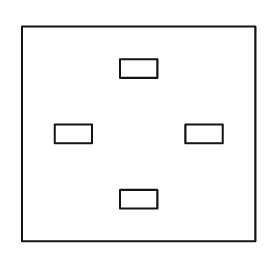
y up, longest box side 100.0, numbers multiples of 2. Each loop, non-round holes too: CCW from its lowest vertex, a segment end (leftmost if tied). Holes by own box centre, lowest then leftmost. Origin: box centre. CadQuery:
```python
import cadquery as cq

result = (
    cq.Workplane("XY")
    .moveTo(-50.0, -46.0)
    .lineTo(50.0, -46.0)
    .lineTo(50.0, 46.0)
    .lineTo(-50.0, 46.0)
    .close()
    .moveTo(-8.0, -32.0)
    .lineTo(8.0, -32.0)
    .lineTo(8.0, -24.0)
    .lineTo(-8.0, -24.0)
    .close()
    .moveTo(-36.0, -4.0)
    .lineTo(-20.0, -4.0)
    .lineTo(-20.0, 4.0)
    .lineTo(-36.0, 4.0)
    .close()
    .moveTo(20.0, -4.0)
    .lineTo(36.0, -4.0)
    .lineTo(36.0, 4.0)
    .lineTo(20.0, 4.0)
    .close()
    .moveTo(-8.0, 24.0)
    .lineTo(8.0, 24.0)
    .lineTo(8.0, 32.0)
    .lineTo(-8.0, 32.0)
    .close()
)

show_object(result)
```